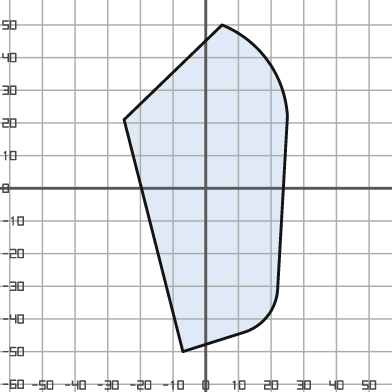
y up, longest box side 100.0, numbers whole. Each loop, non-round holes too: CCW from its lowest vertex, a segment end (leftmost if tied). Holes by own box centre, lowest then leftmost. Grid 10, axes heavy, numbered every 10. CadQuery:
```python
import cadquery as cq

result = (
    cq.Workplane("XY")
    .moveTo(-7.0, -50.0)
    .lineTo(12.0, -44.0)
    .threePointArc((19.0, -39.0), (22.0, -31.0))
    .lineTo(25.0, 22.0)
    .threePointArc((19.0, 39.0), (5.0, 50.0))
    .lineTo(-25.0, 21.0)
    .close()
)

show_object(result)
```